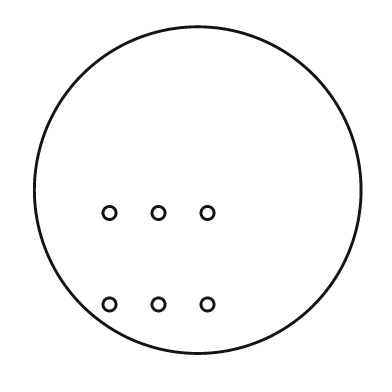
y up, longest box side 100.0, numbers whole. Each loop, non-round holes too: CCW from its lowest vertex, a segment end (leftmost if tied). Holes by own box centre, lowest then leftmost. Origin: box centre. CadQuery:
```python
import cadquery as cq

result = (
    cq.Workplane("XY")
    .moveTo(0.0, 0.0)
    .circle(50.0)
    .moveTo(-27.0, -35.0)
    .circle(2.0)
    .moveTo(-12.0, -35.0)
    .circle(2.0)
    .moveTo(3.0, -35.0)
    .circle(2.0)
    .moveTo(-27.0, -7.0)
    .circle(2.0)
    .moveTo(-12.0, -7.0)
    .circle(2.0)
    .moveTo(3.0, -7.0)
    .circle(2.0)
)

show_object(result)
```